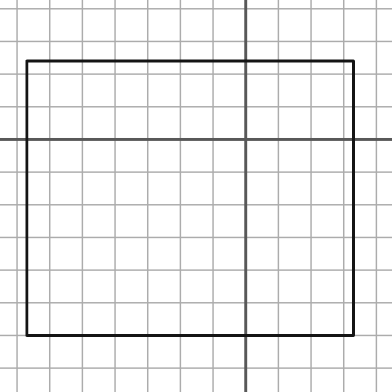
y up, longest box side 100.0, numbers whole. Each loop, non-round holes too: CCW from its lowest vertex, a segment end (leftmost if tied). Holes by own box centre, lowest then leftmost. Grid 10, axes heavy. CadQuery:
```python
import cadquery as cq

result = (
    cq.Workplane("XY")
    .moveTo(-67.0, -60.0)
    .lineTo(33.0, -60.0)
    .lineTo(33.0, 24.0)
    .lineTo(-67.0, 24.0)
    .close()
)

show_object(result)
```